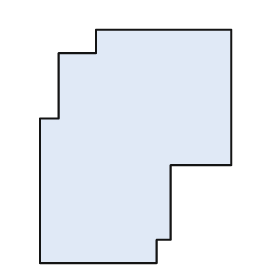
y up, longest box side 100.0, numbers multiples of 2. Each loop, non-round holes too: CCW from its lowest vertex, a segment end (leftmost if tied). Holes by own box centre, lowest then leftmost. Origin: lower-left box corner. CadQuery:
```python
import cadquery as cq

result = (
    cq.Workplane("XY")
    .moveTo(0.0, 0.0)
    .lineTo(50.0, 0.0)
    .lineTo(50.0, 10.0)
    .lineTo(56.0, 10.0)
    .lineTo(56.0, 42.0)
    .lineTo(82.0, 42.0)
    .lineTo(82.0, 100.0)
    .lineTo(24.0, 100.0)
    .lineTo(24.0, 90.0)
    .lineTo(8.0, 90.0)
    .lineTo(8.0, 62.0)
    .lineTo(0.0, 62.0)
    .close()
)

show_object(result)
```